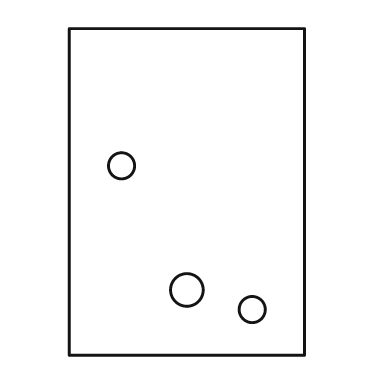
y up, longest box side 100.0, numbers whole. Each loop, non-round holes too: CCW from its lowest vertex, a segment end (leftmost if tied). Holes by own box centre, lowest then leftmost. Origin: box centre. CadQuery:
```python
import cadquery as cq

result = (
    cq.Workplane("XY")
    .moveTo(-36.0, -50.0)
    .lineTo(36.0, -50.0)
    .lineTo(36.0, 50.0)
    .lineTo(-36.0, 50.0)
    .close()
    .moveTo(20.0, -36.0)
    .circle(4.0)
    .moveTo(0.0, -30.0)
    .circle(5.0)
    .moveTo(-20.0, 8.0)
    .circle(4.0)
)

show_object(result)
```